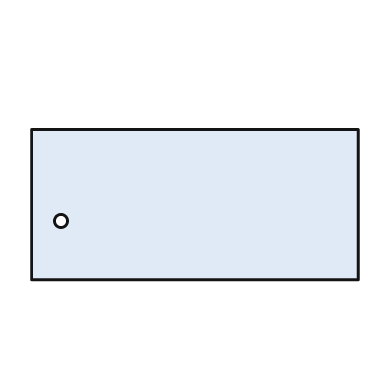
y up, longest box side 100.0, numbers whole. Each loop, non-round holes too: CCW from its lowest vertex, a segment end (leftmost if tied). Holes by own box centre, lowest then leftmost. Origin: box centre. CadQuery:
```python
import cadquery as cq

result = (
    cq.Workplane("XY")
    .moveTo(-50.0, -23.0)
    .lineTo(50.0, -23.0)
    .lineTo(50.0, 23.0)
    .lineTo(-50.0, 23.0)
    .close()
    .moveTo(-41.0, -5.0)
    .circle(2.0)
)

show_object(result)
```